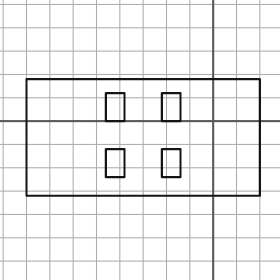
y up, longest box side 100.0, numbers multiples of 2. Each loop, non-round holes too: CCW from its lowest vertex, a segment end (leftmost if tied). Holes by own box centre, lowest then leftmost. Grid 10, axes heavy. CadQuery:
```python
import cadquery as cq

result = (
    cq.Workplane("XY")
    .moveTo(-80.0, -32.0)
    .lineTo(20.0, -32.0)
    .lineTo(20.0, 18.0)
    .lineTo(-80.0, 18.0)
    .close()
    .moveTo(-46.0, -24.0)
    .lineTo(-38.0, -24.0)
    .lineTo(-38.0, -12.0)
    .lineTo(-46.0, -12.0)
    .close()
    .moveTo(-22.0, -24.0)
    .lineTo(-14.0, -24.0)
    .lineTo(-14.0, -12.0)
    .lineTo(-22.0, -12.0)
    .close()
    .moveTo(-46.0, 0.0)
    .lineTo(-38.0, 0.0)
    .lineTo(-38.0, 12.0)
    .lineTo(-46.0, 12.0)
    .close()
    .moveTo(-22.0, 0.0)
    .lineTo(-14.0, 0.0)
    .lineTo(-14.0, 12.0)
    .lineTo(-22.0, 12.0)
    .close()
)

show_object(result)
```